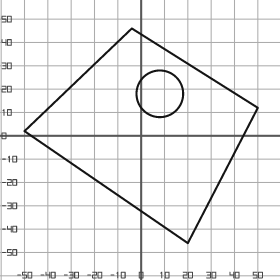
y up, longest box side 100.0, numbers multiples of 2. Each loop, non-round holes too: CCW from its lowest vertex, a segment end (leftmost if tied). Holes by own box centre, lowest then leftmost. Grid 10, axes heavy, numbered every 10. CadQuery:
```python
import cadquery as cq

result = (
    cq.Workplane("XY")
    .moveTo(20.0, -46.0)
    .lineTo(50.0, 12.0)
    .lineTo(-4.0, 46.0)
    .lineTo(-50.0, 2.0)
    .close()
    .moveTo(8.0, 18.0)
    .circle(10.0)
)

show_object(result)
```